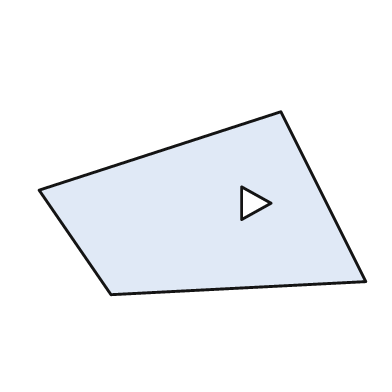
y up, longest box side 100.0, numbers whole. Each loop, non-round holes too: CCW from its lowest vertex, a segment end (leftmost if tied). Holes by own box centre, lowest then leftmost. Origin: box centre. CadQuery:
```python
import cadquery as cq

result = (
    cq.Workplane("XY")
    .moveTo(-28.0, -28.0)
    .lineTo(50.0, -24.0)
    .lineTo(24.0, 28.0)
    .lineTo(-50.0, 4.0)
    .close()
    .moveTo(12.0, -5.0)
    .lineTo(21.0, 0.0)
    .lineTo(12.0, 5.0)
    .close()
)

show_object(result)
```